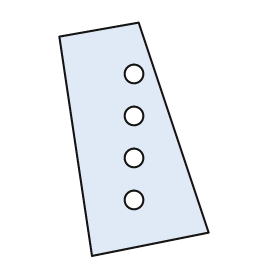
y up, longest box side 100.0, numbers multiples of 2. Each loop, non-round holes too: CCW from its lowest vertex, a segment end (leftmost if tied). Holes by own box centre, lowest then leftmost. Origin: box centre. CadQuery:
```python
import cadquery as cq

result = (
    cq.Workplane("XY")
    .moveTo(-18.0, -50.0)
    .lineTo(32.0, -40.0)
    .lineTo(2.0, 50.0)
    .lineTo(-32.0, 44.0)
    .close()
    .moveTo(0.0, -26.0)
    .circle(4.0)
    .moveTo(0.0, -8.0)
    .circle(4.0)
    .moveTo(0.0, 10.0)
    .circle(4.0)
    .moveTo(0.0, 28.0)
    .circle(4.0)
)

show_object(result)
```